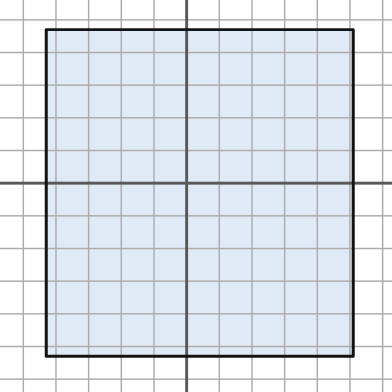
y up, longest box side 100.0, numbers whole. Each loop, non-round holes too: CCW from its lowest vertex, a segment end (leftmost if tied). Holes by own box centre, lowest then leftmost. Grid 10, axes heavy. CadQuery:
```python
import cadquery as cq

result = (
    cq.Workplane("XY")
    .moveTo(-43.0, -53.0)
    .lineTo(51.0, -53.0)
    .lineTo(51.0, 47.0)
    .lineTo(-43.0, 47.0)
    .close()
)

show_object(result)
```